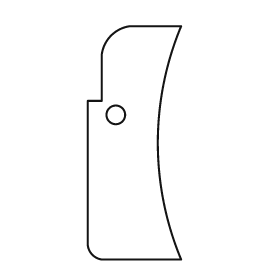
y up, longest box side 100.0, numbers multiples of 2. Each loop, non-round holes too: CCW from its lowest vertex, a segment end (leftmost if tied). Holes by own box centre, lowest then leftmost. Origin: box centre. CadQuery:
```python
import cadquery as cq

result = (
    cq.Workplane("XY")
    .moveTo(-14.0, -50.0)
    .lineTo(20.0, -50.0)
    .threePointArc((10.0, 0.0), (20.0, 50.0))
    .lineTo(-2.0, 50.0)
    .threePointArc((-10.0, 46.0), (-14.0, 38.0))
    .lineTo(-14.0, 18.0)
    .lineTo(-20.0, 18.0)
    .lineTo(-20.0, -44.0)
    .threePointArc((-18.0, -48.0), (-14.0, -50.0))
    .close()
    .moveTo(-8.0, 12.0)
    .circle(4.0)
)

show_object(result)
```